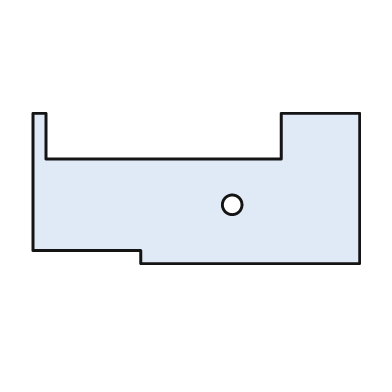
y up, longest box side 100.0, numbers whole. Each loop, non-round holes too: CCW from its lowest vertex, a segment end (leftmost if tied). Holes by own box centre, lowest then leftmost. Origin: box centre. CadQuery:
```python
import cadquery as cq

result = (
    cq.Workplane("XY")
    .moveTo(-17.0, -23.0)
    .lineTo(50.0, -23.0)
    .lineTo(50.0, 23.0)
    .lineTo(26.0, 23.0)
    .lineTo(26.0, 9.0)
    .lineTo(-46.0, 9.0)
    .lineTo(-46.0, 23.0)
    .lineTo(-50.0, 23.0)
    .lineTo(-50.0, -19.0)
    .lineTo(-17.0, -19.0)
    .close()
    .moveTo(11.0, -5.0)
    .circle(3.0)
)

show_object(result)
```